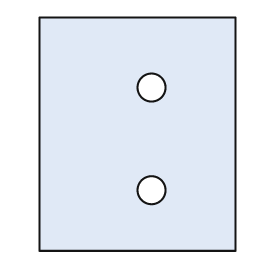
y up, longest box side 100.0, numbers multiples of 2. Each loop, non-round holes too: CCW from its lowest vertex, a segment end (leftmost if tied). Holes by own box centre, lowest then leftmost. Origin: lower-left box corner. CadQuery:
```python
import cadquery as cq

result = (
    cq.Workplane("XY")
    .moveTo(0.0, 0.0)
    .lineTo(84.0, 0.0)
    .lineTo(84.0, 100.0)
    .lineTo(0.0, 100.0)
    .close()
    .moveTo(48.0, 26.0)
    .circle(6.0)
    .moveTo(48.0, 70.0)
    .circle(6.0)
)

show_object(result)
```